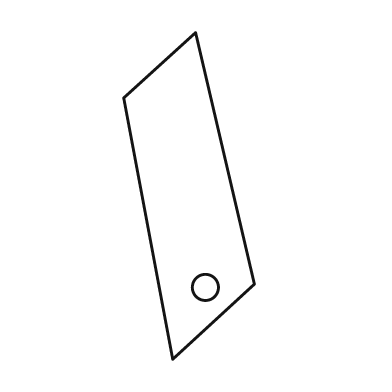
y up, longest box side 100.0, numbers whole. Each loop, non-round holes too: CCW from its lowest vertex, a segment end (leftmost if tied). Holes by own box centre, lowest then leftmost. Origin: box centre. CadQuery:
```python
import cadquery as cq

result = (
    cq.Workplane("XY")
    .moveTo(-5.0, -50.0)
    .lineTo(20.0, -27.0)
    .lineTo(2.0, 50.0)
    .lineTo(-20.0, 30.0)
    .close()
    .moveTo(5.0, -28.0)
    .circle(4.0)
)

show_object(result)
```